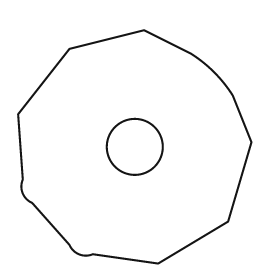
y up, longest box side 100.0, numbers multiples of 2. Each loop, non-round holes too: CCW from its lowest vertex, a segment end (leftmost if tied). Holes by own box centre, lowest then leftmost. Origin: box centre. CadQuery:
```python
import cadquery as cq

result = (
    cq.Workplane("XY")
    .moveTo(10.0, -50.0)
    .lineTo(40.0, -32.0)
    .lineTo(50.0, 2.0)
    .lineTo(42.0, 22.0)
    .threePointArc((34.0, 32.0), (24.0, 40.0))
    .lineTo(4.0, 50.0)
    .lineTo(-28.0, 42.0)
    .lineTo(-50.0, 14.0)
    .lineTo(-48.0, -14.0)
    .threePointArc((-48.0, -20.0), (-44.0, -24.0))
    .lineTo(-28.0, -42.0)
    .threePointArc((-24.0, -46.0), (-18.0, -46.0))
    .close()
    .moveTo(0.0, 0.0)
    .circle(12.0)
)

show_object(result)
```